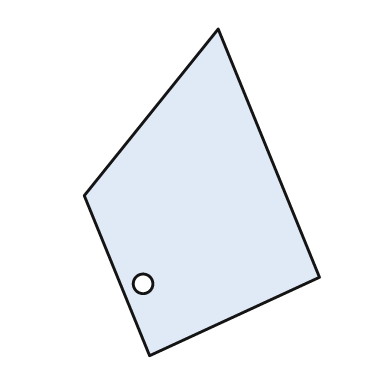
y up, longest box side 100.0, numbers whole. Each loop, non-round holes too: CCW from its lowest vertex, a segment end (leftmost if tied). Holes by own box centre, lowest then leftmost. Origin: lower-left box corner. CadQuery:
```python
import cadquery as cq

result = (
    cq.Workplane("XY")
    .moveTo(20.0, 0.0)
    .lineTo(72.0, 24.0)
    .lineTo(41.0, 100.0)
    .lineTo(0.0, 49.0)
    .close()
    .moveTo(18.0, 22.0)
    .circle(3.0)
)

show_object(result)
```